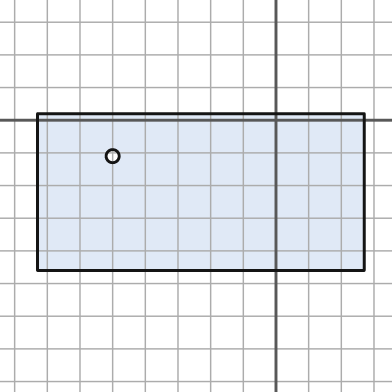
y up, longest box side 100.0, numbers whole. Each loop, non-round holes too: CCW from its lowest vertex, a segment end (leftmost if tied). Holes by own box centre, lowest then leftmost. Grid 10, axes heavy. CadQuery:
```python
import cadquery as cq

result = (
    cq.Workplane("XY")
    .moveTo(-73.0, -46.0)
    .lineTo(27.0, -46.0)
    .lineTo(27.0, 2.0)
    .lineTo(-73.0, 2.0)
    .close()
    .moveTo(-50.0, -11.0)
    .circle(2.0)
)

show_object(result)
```